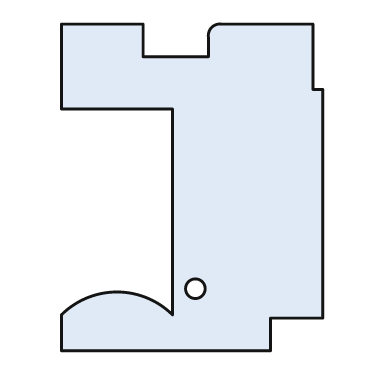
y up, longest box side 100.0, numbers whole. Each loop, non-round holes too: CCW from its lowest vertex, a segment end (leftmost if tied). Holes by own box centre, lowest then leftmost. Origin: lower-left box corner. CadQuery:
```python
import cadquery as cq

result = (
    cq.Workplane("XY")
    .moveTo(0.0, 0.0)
    .lineTo(64.0, 0.0)
    .lineTo(64.0, 10.0)
    .lineTo(80.0, 10.0)
    .lineTo(80.0, 80.0)
    .lineTo(77.0, 80.0)
    .lineTo(77.0, 100.0)
    .lineTo(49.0, 100.0)
    .threePointArc((46.0, 99.0), (45.0, 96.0))
    .lineTo(45.0, 90.0)
    .lineTo(25.0, 90.0)
    .lineTo(25.0, 100.0)
    .lineTo(0.0, 100.0)
    .lineTo(0.0, 74.0)
    .lineTo(34.0, 74.0)
    .lineTo(34.0, 11.0)
    .threePointArc((17.0, 18.0), (0.0, 11.0))
    .close()
    .moveTo(41.0, 19.0)
    .circle(3.0)
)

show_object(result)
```